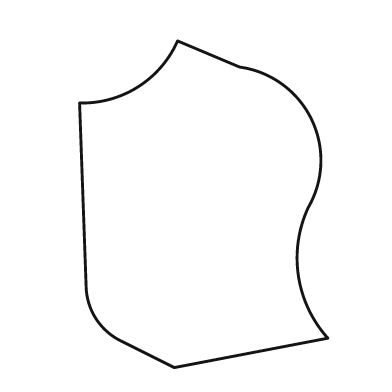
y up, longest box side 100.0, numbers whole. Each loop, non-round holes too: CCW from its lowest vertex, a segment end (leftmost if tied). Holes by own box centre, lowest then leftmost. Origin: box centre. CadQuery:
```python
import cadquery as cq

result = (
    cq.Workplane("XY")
    .moveTo(-9.0, -50.0)
    .lineTo(38.0, -41.0)
    .threePointArc((29.0, -22.0), (32.0, -1.0))
    .threePointArc((33.0, 26.0), (11.0, 42.0))
    .lineTo(-8.0, 50.0)
    .threePointArc((-20.0, 36.0), (-38.0, 31.0))
    .lineTo(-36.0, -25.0)
    .threePointArc((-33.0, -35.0), (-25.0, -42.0))
    .close()
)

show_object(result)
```